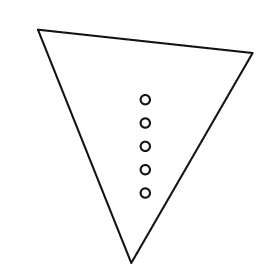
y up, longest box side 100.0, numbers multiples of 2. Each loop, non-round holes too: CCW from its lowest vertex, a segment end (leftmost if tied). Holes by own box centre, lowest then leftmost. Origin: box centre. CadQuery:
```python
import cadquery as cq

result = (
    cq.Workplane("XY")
    .moveTo(-6.0, -50.0)
    .lineTo(46.0, 40.0)
    .lineTo(-46.0, 50.0)
    .close()
    .moveTo(0.0, -20.0)
    .circle(2.0)
    .moveTo(0.0, -10.0)
    .circle(2.0)
    .moveTo(0.0, 0.0)
    .circle(2.0)
    .moveTo(0.0, 10.0)
    .circle(2.0)
    .moveTo(0.0, 20.0)
    .circle(2.0)
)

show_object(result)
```